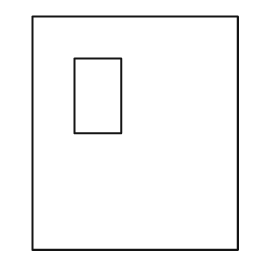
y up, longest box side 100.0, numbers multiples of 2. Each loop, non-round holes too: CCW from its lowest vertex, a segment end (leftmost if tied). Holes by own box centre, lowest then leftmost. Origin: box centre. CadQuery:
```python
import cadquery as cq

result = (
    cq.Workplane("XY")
    .moveTo(-44.0, -50.0)
    .lineTo(44.0, -50.0)
    .lineTo(44.0, 50.0)
    .lineTo(-44.0, 50.0)
    .close()
    .moveTo(-26.0, 0.0)
    .lineTo(-6.0, 0.0)
    .lineTo(-6.0, 32.0)
    .lineTo(-26.0, 32.0)
    .close()
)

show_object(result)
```